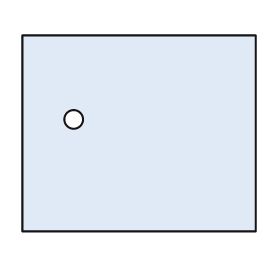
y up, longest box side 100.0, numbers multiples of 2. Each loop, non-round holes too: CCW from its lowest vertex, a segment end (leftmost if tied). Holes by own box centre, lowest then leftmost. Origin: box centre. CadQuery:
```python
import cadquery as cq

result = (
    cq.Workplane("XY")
    .moveTo(-50.0, -42.0)
    .lineTo(50.0, -42.0)
    .lineTo(50.0, 42.0)
    .lineTo(-50.0, 42.0)
    .close()
    .moveTo(-28.0, 6.0)
    .circle(4.0)
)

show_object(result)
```